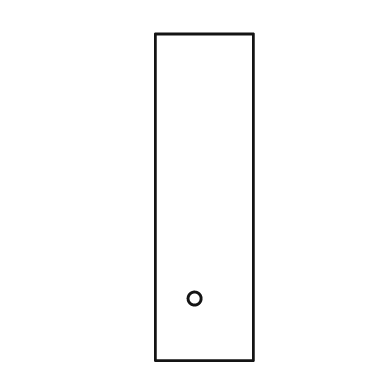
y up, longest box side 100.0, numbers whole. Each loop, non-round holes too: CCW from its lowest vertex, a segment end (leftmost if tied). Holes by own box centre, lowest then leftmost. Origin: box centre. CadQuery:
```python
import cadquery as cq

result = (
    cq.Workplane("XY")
    .moveTo(-15.0, -50.0)
    .lineTo(15.0, -50.0)
    .lineTo(15.0, 50.0)
    .lineTo(-15.0, 50.0)
    .close()
    .moveTo(-3.0, -31.0)
    .circle(2.0)
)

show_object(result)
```